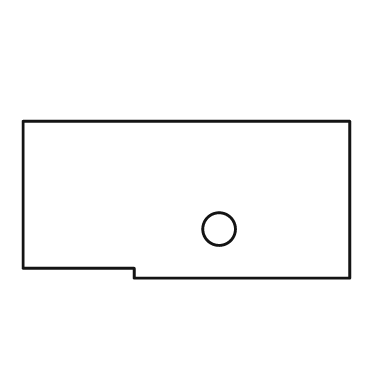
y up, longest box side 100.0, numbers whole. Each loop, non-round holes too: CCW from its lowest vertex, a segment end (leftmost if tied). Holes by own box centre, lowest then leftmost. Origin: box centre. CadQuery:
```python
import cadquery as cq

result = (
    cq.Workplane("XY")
    .moveTo(-16.0, -24.0)
    .lineTo(50.0, -24.0)
    .lineTo(50.0, 24.0)
    .lineTo(-50.0, 24.0)
    .lineTo(-50.0, -21.0)
    .lineTo(-16.0, -21.0)
    .close()
    .moveTo(10.0, -9.0)
    .circle(5.0)
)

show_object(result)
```